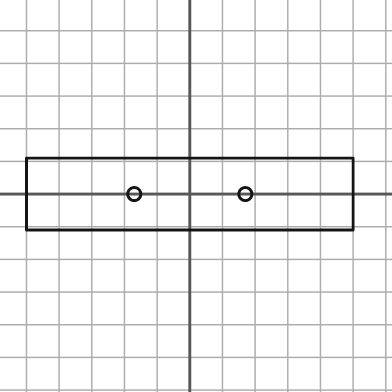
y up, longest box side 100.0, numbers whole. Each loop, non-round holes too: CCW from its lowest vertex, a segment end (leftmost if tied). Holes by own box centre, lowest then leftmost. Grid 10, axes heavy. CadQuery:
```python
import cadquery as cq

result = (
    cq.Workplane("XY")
    .moveTo(-50.0, -11.0)
    .lineTo(50.0, -11.0)
    .lineTo(50.0, 11.0)
    .lineTo(-50.0, 11.0)
    .close()
    .moveTo(-17.0, 0.0)
    .circle(2.0)
    .moveTo(17.0, 0.0)
    .circle(2.0)
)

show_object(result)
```